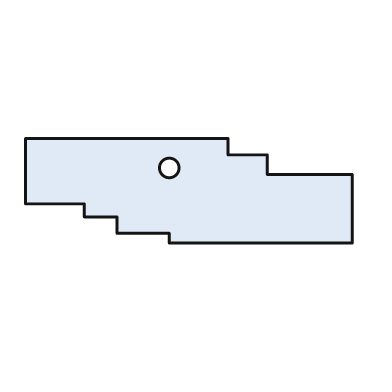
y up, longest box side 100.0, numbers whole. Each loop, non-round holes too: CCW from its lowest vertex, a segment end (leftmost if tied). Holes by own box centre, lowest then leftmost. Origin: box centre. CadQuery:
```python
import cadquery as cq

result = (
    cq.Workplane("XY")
    .moveTo(-6.0, -16.0)
    .lineTo(50.0, -16.0)
    .lineTo(50.0, 5.0)
    .lineTo(24.0, 5.0)
    .lineTo(24.0, 11.0)
    .lineTo(12.0, 11.0)
    .lineTo(12.0, 16.0)
    .lineTo(-50.0, 16.0)
    .lineTo(-50.0, -4.0)
    .lineTo(-32.0, -4.0)
    .lineTo(-32.0, -8.0)
    .lineTo(-22.0, -8.0)
    .lineTo(-22.0, -13.0)
    .lineTo(-6.0, -13.0)
    .close()
    .moveTo(-6.0, 7.0)
    .circle(3.0)
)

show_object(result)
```